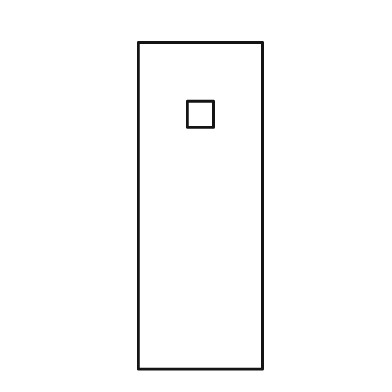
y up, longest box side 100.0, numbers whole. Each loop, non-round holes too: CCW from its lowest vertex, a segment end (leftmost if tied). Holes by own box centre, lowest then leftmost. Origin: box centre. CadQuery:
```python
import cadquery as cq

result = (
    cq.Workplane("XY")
    .moveTo(-19.0, -50.0)
    .lineTo(19.0, -50.0)
    .lineTo(19.0, 50.0)
    .lineTo(-19.0, 50.0)
    .close()
    .moveTo(-4.0, 24.0)
    .lineTo(4.0, 24.0)
    .lineTo(4.0, 32.0)
    .lineTo(-4.0, 32.0)
    .close()
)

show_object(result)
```